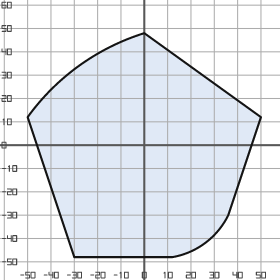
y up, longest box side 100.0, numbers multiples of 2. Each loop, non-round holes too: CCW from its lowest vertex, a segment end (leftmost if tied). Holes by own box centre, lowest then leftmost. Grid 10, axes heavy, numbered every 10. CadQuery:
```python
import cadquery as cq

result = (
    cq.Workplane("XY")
    .moveTo(-30.0, -48.0)
    .lineTo(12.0, -48.0)
    .threePointArc((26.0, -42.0), (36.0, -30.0))
    .lineTo(50.0, 12.0)
    .lineTo(0.0, 48.0)
    .threePointArc((-28.0, 34.0), (-50.0, 12.0))
    .close()
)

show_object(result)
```